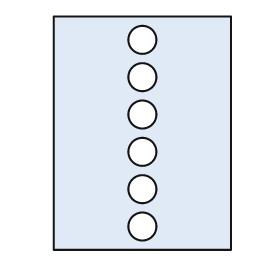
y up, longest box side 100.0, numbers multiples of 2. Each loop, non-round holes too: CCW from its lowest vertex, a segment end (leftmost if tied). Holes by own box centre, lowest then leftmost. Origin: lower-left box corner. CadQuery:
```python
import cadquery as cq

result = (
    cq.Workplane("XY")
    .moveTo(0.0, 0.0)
    .lineTo(76.0, 0.0)
    .lineTo(76.0, 100.0)
    .lineTo(0.0, 100.0)
    .close()
    .moveTo(38.0, 10.0)
    .circle(6.0)
    .moveTo(38.0, 26.0)
    .circle(6.0)
    .moveTo(38.0, 42.0)
    .circle(6.0)
    .moveTo(38.0, 58.0)
    .circle(6.0)
    .moveTo(38.0, 74.0)
    .circle(6.0)
    .moveTo(38.0, 90.0)
    .circle(6.0)
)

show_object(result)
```